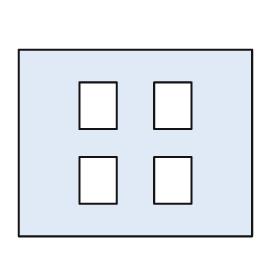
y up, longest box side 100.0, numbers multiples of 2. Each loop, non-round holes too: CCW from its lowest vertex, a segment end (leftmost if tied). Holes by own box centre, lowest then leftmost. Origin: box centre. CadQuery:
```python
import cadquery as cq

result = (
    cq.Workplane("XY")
    .moveTo(-50.0, -40.0)
    .lineTo(50.0, -40.0)
    .lineTo(50.0, 40.0)
    .lineTo(-50.0, 40.0)
    .close()
    .moveTo(-24.0, -26.0)
    .lineTo(-8.0, -26.0)
    .lineTo(-8.0, -6.0)
    .lineTo(-24.0, -6.0)
    .close()
    .moveTo(8.0, -26.0)
    .lineTo(24.0, -26.0)
    .lineTo(24.0, -6.0)
    .lineTo(8.0, -6.0)
    .close()
    .moveTo(-24.0, 6.0)
    .lineTo(-8.0, 6.0)
    .lineTo(-8.0, 26.0)
    .lineTo(-24.0, 26.0)
    .close()
    .moveTo(8.0, 6.0)
    .lineTo(24.0, 6.0)
    .lineTo(24.0, 26.0)
    .lineTo(8.0, 26.0)
    .close()
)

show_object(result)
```